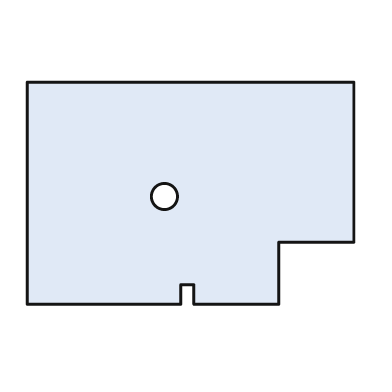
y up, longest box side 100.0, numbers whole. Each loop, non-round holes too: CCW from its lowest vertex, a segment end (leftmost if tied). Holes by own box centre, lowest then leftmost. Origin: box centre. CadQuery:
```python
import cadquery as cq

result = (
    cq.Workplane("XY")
    .moveTo(-50.0, -34.0)
    .lineTo(-3.0, -34.0)
    .lineTo(-3.0, -28.0)
    .lineTo(1.0, -28.0)
    .lineTo(1.0, -34.0)
    .lineTo(27.0, -34.0)
    .lineTo(27.0, -15.0)
    .lineTo(50.0, -15.0)
    .lineTo(50.0, 34.0)
    .lineTo(-50.0, 34.0)
    .close()
    .moveTo(-8.0, -1.0)
    .circle(4.0)
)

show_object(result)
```